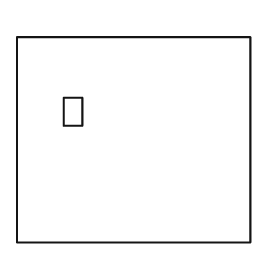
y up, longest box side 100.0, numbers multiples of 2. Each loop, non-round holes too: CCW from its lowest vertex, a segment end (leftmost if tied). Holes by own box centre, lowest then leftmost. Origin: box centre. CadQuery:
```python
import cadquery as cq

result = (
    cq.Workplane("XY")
    .moveTo(-50.0, -44.0)
    .lineTo(50.0, -44.0)
    .lineTo(50.0, 44.0)
    .lineTo(-50.0, 44.0)
    .close()
    .moveTo(-30.0, 6.0)
    .lineTo(-22.0, 6.0)
    .lineTo(-22.0, 18.0)
    .lineTo(-30.0, 18.0)
    .close()
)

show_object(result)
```